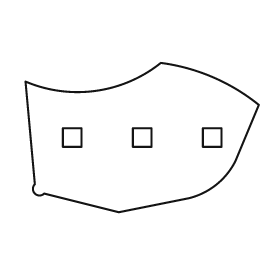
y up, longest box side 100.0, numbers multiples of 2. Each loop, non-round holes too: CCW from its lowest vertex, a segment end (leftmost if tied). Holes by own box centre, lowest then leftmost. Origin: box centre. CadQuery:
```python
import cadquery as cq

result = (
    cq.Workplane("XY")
    .moveTo(-10.0, -32.0)
    .lineTo(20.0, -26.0)
    .threePointArc((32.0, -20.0), (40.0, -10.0))
    .lineTo(50.0, 14.0)
    .threePointArc((30.0, 26.0), (8.0, 32.0))
    .threePointArc((-20.0, 20.0), (-50.0, 24.0))
    .lineTo(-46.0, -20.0)
    .threePointArc((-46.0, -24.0), (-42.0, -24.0))
    .close()
    .moveTo(-34.0, -4.0)
    .lineTo(-26.0, -4.0)
    .lineTo(-26.0, 4.0)
    .lineTo(-34.0, 4.0)
    .close()
    .moveTo(-4.0, -4.0)
    .lineTo(4.0, -4.0)
    .lineTo(4.0, 4.0)
    .lineTo(-4.0, 4.0)
    .close()
    .moveTo(26.0, -4.0)
    .lineTo(34.0, -4.0)
    .lineTo(34.0, 4.0)
    .lineTo(26.0, 4.0)
    .close()
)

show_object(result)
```